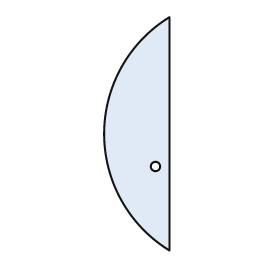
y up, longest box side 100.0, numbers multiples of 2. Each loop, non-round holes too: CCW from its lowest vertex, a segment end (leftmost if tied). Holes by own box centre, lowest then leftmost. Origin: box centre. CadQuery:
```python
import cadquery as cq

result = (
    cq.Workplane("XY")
    .moveTo(14.0, -50.0)
    .lineTo(14.0, 50.0)
    .threePointArc((-14.0, 0.0), (14.0, -50.0))
    .close()
    .moveTo(8.0, -14.0)
    .circle(2.0)
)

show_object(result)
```